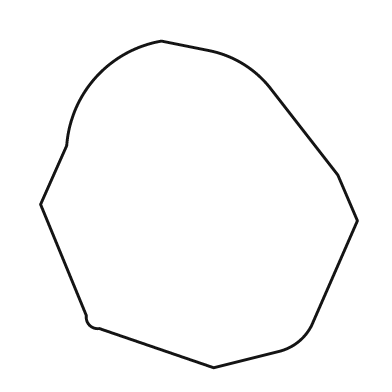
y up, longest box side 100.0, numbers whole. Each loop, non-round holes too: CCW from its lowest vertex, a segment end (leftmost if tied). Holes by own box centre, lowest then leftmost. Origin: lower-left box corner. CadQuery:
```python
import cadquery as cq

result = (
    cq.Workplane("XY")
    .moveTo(53.0, 0.0)
    .lineTo(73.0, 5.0)
    .threePointArc((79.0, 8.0), (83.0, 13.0))
    .lineTo(97.0, 45.0)
    .lineTo(91.0, 59.0)
    .lineTo(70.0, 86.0)
    .threePointArc((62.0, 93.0), (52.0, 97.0))
    .lineTo(37.0, 100.0)
    .threePointArc((17.0, 89.0), (8.0, 68.0))
    .lineTo(0.0, 50.0)
    .lineTo(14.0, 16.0)
    .threePointArc((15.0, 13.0), (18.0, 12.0))
    .close()
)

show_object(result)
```